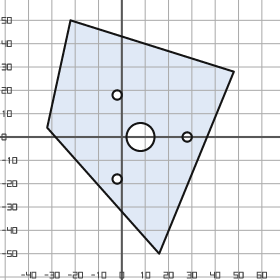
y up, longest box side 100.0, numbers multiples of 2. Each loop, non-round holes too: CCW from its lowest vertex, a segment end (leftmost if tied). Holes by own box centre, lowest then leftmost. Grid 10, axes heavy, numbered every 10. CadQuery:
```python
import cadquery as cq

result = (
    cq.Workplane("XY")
    .moveTo(16.0, -50.0)
    .lineTo(48.0, 28.0)
    .lineTo(-22.0, 50.0)
    .lineTo(-32.0, 4.0)
    .close()
    .moveTo(-2.0, -18.0)
    .circle(2.0)
    .moveTo(8.0, 0.0)
    .circle(6.0)
    .moveTo(28.0, 0.0)
    .circle(2.0)
    .moveTo(-2.0, 18.0)
    .circle(2.0)
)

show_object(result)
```